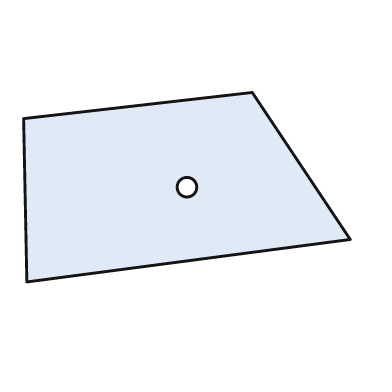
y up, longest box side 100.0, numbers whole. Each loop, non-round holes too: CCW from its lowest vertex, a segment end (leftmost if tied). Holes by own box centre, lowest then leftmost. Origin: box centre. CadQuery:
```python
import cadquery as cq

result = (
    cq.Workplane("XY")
    .moveTo(-49.0, -29.0)
    .lineTo(50.0, -16.0)
    .lineTo(20.0, 29.0)
    .lineTo(-50.0, 21.0)
    .close()
    .moveTo(0.0, 0.0)
    .circle(3.0)
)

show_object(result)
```